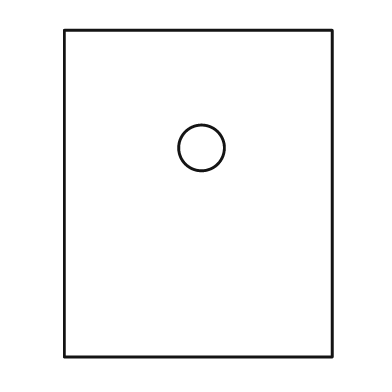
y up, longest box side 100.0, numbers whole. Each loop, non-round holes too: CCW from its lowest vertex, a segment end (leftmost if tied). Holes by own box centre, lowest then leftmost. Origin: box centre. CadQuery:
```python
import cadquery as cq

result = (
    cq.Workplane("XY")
    .moveTo(-41.0, -50.0)
    .lineTo(41.0, -50.0)
    .lineTo(41.0, 50.0)
    .lineTo(-41.0, 50.0)
    .close()
    .moveTo(1.0, 14.0)
    .circle(7.0)
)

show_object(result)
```